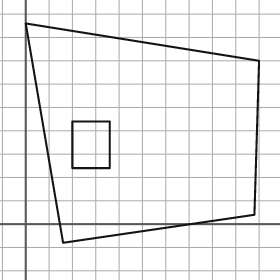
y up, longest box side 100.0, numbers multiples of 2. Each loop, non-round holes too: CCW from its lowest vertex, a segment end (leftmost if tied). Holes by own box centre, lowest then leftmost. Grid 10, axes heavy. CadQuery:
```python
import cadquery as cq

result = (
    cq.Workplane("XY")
    .moveTo(16.0, -8.0)
    .lineTo(98.0, 4.0)
    .lineTo(100.0, 70.0)
    .lineTo(0.0, 86.0)
    .close()
    .moveTo(20.0, 24.0)
    .lineTo(36.0, 24.0)
    .lineTo(36.0, 44.0)
    .lineTo(20.0, 44.0)
    .close()
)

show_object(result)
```